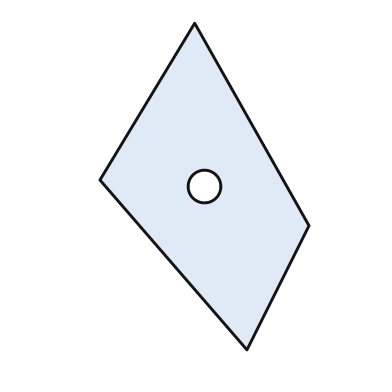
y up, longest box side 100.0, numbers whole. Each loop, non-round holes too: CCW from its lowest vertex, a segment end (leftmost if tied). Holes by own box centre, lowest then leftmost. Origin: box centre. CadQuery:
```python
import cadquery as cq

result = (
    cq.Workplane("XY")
    .moveTo(13.0, -50.0)
    .lineTo(32.0, -12.0)
    .lineTo(-3.0, 50.0)
    .lineTo(-32.0, 2.0)
    .close()
    .moveTo(0.0, 0.0)
    .circle(5.0)
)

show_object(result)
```